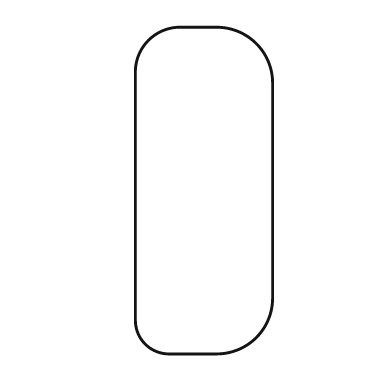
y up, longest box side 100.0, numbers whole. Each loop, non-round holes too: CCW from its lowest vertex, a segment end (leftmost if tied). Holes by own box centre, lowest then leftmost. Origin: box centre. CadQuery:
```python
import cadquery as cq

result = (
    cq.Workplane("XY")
    .moveTo(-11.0, -50.0)
    .lineTo(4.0, -50.0)
    .threePointArc((16.0, -45.0), (21.0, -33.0))
    .lineTo(21.0, 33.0)
    .threePointArc((16.0, 45.0), (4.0, 50.0))
    .lineTo(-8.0, 50.0)
    .threePointArc((-17.0, 46.0), (-21.0, 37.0))
    .lineTo(-21.0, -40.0)
    .threePointArc((-18.0, -47.0), (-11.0, -50.0))
    .close()
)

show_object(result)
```